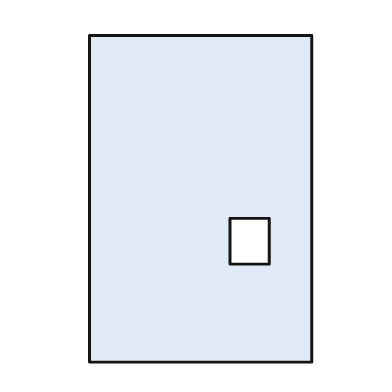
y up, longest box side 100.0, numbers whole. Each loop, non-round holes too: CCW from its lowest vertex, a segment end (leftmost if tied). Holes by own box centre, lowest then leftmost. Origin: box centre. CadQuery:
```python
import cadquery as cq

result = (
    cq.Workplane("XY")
    .moveTo(-34.0, -50.0)
    .lineTo(34.0, -50.0)
    .lineTo(34.0, 50.0)
    .lineTo(-34.0, 50.0)
    .close()
    .moveTo(9.0, -20.0)
    .lineTo(21.0, -20.0)
    .lineTo(21.0, -6.0)
    .lineTo(9.0, -6.0)
    .close()
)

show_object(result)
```